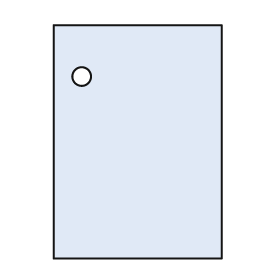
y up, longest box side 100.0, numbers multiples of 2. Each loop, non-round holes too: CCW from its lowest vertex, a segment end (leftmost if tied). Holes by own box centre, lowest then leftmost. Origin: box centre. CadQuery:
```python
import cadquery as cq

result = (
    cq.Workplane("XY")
    .moveTo(-36.0, -50.0)
    .lineTo(36.0, -50.0)
    .lineTo(36.0, 50.0)
    .lineTo(-36.0, 50.0)
    .close()
    .moveTo(-24.0, 28.0)
    .circle(4.0)
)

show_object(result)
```